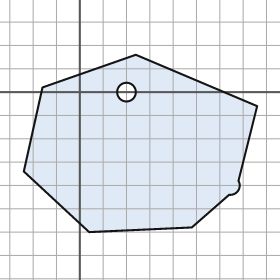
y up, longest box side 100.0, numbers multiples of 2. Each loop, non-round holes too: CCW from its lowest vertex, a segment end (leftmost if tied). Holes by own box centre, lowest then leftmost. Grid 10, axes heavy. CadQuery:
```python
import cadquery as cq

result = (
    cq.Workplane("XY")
    .moveTo(4.0, -60.0)
    .lineTo(48.0, -58.0)
    .lineTo(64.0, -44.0)
    .threePointArc((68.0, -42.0), (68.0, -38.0))
    .lineTo(76.0, -6.0)
    .lineTo(24.0, 16.0)
    .lineTo(-16.0, 2.0)
    .lineTo(-24.0, -34.0)
    .close()
    .moveTo(20.0, 0.0)
    .circle(4.0)
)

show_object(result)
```